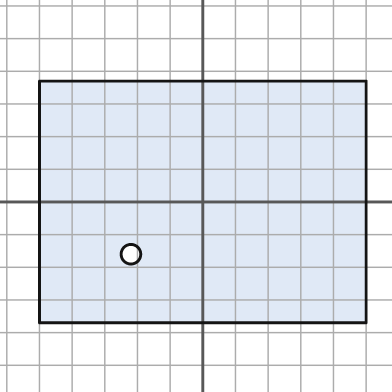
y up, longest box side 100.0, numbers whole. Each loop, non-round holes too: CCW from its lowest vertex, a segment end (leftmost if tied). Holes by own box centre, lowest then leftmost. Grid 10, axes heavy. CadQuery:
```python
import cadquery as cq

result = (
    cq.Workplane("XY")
    .moveTo(-50.0, -37.0)
    .lineTo(50.0, -37.0)
    .lineTo(50.0, 37.0)
    .lineTo(-50.0, 37.0)
    .close()
    .moveTo(-22.0, -16.0)
    .circle(3.0)
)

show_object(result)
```